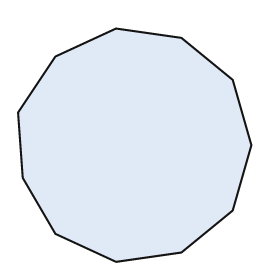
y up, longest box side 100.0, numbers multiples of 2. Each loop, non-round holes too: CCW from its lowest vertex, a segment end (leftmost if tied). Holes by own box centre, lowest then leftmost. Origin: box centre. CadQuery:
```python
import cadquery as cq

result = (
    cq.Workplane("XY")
    .moveTo(-8.0, -50.0)
    .lineTo(20.0, -46.0)
    .lineTo(42.0, -28.0)
    .lineTo(50.0, 0.0)
    .lineTo(42.0, 28.0)
    .lineTo(20.0, 46.0)
    .lineTo(-8.0, 50.0)
    .lineTo(-34.0, 38.0)
    .lineTo(-50.0, 14.0)
    .lineTo(-48.0, -14.0)
    .lineTo(-34.0, -38.0)
    .close()
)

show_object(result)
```